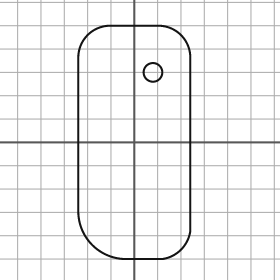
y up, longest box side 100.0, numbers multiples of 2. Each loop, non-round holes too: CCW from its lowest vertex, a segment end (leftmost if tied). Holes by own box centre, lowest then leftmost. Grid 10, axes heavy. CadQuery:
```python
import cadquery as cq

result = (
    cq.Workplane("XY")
    .moveTo(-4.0, -50.0)
    .lineTo(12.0, -50.0)
    .threePointArc((20.0, -46.0), (24.0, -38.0))
    .lineTo(24.0, 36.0)
    .threePointArc((20.0, 46.0), (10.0, 50.0))
    .lineTo(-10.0, 50.0)
    .threePointArc((-20.0, 46.0), (-24.0, 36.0))
    .lineTo(-24.0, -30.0)
    .threePointArc((-18.0, -44.0), (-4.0, -50.0))
    .close()
    .moveTo(8.0, 30.0)
    .circle(4.0)
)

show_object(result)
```